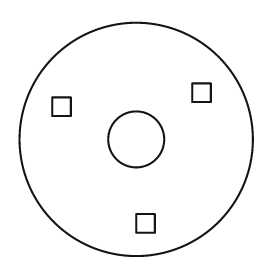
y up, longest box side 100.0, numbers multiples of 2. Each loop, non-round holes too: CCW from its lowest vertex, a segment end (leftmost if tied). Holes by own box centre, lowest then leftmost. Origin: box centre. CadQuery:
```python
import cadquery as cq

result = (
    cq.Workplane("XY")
    .moveTo(0.0, 0.0)
    .circle(50.0)
    .moveTo(0.0, -40.0)
    .lineTo(8.0, -40.0)
    .lineTo(8.0, -32.0)
    .lineTo(0.0, -32.0)
    .close()
    .moveTo(0.0, 0.0)
    .circle(12.0)
    .moveTo(-36.0, 10.0)
    .lineTo(-28.0, 10.0)
    .lineTo(-28.0, 18.0)
    .lineTo(-36.0, 18.0)
    .close()
    .moveTo(24.0, 16.0)
    .lineTo(32.0, 16.0)
    .lineTo(32.0, 24.0)
    .lineTo(24.0, 24.0)
    .close()
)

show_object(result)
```